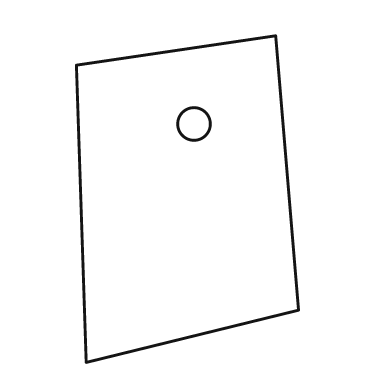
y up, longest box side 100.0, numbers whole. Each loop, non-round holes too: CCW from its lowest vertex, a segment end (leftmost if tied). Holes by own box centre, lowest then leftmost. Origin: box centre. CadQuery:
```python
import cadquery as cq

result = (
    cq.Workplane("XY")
    .moveTo(-31.0, -50.0)
    .lineTo(34.0, -34.0)
    .lineTo(27.0, 50.0)
    .lineTo(-34.0, 41.0)
    .close()
    .moveTo(2.0, 23.0)
    .circle(5.0)
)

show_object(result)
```